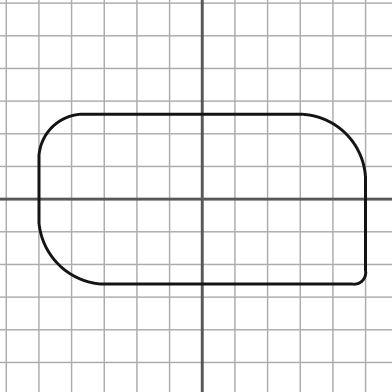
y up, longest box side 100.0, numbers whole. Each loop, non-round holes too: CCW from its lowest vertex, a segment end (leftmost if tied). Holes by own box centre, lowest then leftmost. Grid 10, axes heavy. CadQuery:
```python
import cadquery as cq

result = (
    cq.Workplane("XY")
    .moveTo(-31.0, -26.0)
    .lineTo(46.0, -26.0)
    .threePointArc((49.0, -25.0), (50.0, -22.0))
    .lineTo(50.0, 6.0)
    .threePointArc((44.0, 20.0), (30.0, 26.0))
    .lineTo(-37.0, 26.0)
    .threePointArc((-46.0, 22.0), (-50.0, 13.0))
    .lineTo(-50.0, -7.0)
    .threePointArc((-44.0, -20.0), (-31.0, -26.0))
    .close()
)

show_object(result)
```